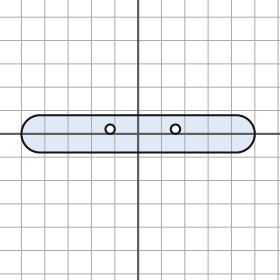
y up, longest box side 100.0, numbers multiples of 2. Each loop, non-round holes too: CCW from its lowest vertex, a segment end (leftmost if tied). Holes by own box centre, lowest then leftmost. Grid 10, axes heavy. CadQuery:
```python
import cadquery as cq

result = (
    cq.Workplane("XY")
    .moveTo(-42.0, -8.0)
    .lineTo(42.0, -8.0)
    .threePointArc((50.0, 0.0), (42.0, 8.0))
    .lineTo(-42.0, 8.0)
    .threePointArc((-50.0, 0.0), (-42.0, -8.0))
    .close()
    .moveTo(-12.0, 2.0)
    .circle(2.0)
    .moveTo(16.0, 2.0)
    .circle(2.0)
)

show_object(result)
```